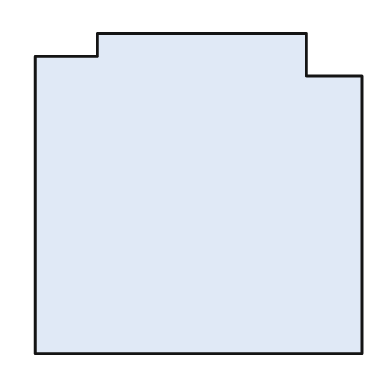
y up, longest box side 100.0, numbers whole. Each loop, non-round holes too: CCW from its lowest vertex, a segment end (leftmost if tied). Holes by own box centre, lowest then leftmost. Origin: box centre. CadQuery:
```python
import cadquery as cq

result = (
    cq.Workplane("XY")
    .moveTo(-50.0, -49.0)
    .lineTo(50.0, -49.0)
    .lineTo(50.0, 36.0)
    .lineTo(33.0, 36.0)
    .lineTo(33.0, 49.0)
    .lineTo(-31.0, 49.0)
    .lineTo(-31.0, 42.0)
    .lineTo(-50.0, 42.0)
    .close()
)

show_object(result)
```